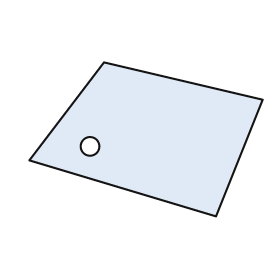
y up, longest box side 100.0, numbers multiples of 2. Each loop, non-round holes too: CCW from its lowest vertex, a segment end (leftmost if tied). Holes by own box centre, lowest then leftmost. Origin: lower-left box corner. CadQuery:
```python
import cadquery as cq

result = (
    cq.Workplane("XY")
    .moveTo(80.0, 0.0)
    .lineTo(100.0, 50.0)
    .lineTo(32.0, 66.0)
    .lineTo(0.0, 24.0)
    .close()
    .moveTo(26.0, 30.0)
    .circle(4.0)
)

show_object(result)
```